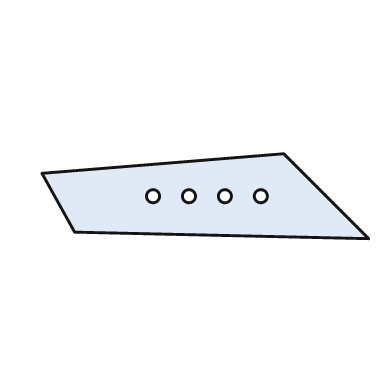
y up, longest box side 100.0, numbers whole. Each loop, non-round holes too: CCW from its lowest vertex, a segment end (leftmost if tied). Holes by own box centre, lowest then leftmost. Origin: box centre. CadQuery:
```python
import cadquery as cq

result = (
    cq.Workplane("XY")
    .moveTo(50.0, -13.0)
    .lineTo(24.0, 13.0)
    .lineTo(-50.0, 7.0)
    .lineTo(-40.0, -11.0)
    .close()
    .moveTo(-16.0, 0.0)
    .circle(2.0)
    .moveTo(-5.0, 0.0)
    .circle(2.0)
    .moveTo(6.0, 0.0)
    .circle(2.0)
    .moveTo(17.0, 0.0)
    .circle(2.0)
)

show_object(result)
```